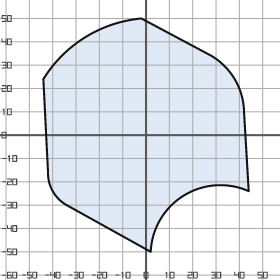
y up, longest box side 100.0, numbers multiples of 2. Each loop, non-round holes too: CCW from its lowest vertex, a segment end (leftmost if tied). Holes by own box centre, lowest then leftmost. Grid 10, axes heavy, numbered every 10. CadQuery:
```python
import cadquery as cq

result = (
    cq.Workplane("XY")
    .moveTo(2.0, -50.0)
    .threePointArc((16.0, -26.0), (44.0, -24.0))
    .lineTo(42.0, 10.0)
    .threePointArc((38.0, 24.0), (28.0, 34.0))
    .lineTo(-2.0, 50.0)
    .threePointArc((-26.0, 42.0), (-44.0, 24.0))
    .lineTo(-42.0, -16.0)
    .threePointArc((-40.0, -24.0), (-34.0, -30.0))
    .close()
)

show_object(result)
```